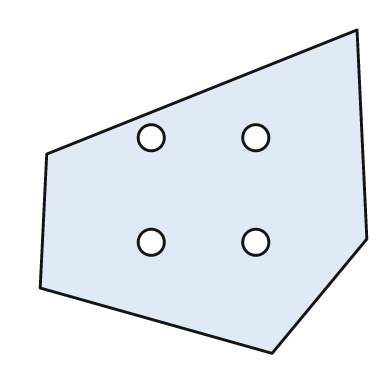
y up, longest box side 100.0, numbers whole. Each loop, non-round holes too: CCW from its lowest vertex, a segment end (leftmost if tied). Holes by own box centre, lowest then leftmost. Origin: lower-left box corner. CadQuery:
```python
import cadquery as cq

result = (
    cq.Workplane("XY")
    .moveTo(71.0, 0.0)
    .lineTo(100.0, 35.0)
    .lineTo(97.0, 99.0)
    .lineTo(2.0, 61.0)
    .lineTo(0.0, 20.0)
    .close()
    .moveTo(34.0, 34.0)
    .circle(4.0)
    .moveTo(66.0, 34.0)
    .circle(4.0)
    .moveTo(34.0, 66.0)
    .circle(4.0)
    .moveTo(66.0, 66.0)
    .circle(4.0)
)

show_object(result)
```